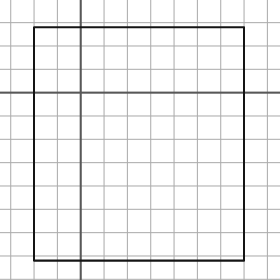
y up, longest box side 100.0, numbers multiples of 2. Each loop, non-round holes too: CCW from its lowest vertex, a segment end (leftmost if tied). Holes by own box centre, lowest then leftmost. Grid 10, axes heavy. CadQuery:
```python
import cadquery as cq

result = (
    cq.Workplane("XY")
    .moveTo(-20.0, -72.0)
    .lineTo(70.0, -72.0)
    .lineTo(70.0, 28.0)
    .lineTo(-20.0, 28.0)
    .close()
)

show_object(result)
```